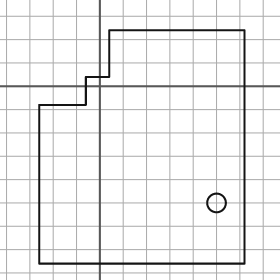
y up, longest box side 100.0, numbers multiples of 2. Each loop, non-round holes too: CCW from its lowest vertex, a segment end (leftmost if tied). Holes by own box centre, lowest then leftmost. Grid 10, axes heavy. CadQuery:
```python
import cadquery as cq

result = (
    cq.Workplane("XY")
    .moveTo(-26.0, -76.0)
    .lineTo(62.0, -76.0)
    .lineTo(62.0, 24.0)
    .lineTo(4.0, 24.0)
    .lineTo(4.0, 4.0)
    .lineTo(-6.0, 4.0)
    .lineTo(-6.0, -8.0)
    .lineTo(-26.0, -8.0)
    .close()
    .moveTo(50.0, -50.0)
    .circle(4.0)
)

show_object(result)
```